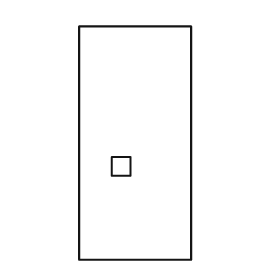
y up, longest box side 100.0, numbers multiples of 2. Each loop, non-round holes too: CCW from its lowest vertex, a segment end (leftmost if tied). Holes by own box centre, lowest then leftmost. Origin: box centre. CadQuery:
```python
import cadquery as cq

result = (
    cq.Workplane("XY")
    .moveTo(-24.0, -50.0)
    .lineTo(24.0, -50.0)
    .lineTo(24.0, 50.0)
    .lineTo(-24.0, 50.0)
    .close()
    .moveTo(-10.0, -14.0)
    .lineTo(-2.0, -14.0)
    .lineTo(-2.0, -6.0)
    .lineTo(-10.0, -6.0)
    .close()
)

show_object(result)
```